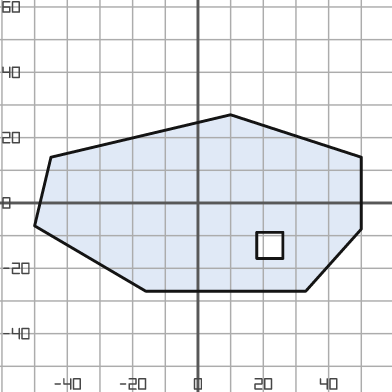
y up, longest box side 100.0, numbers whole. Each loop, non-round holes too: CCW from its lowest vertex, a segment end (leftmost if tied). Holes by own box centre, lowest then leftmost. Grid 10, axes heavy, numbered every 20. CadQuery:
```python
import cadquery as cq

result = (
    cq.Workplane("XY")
    .moveTo(-16.0, -27.0)
    .lineTo(33.0, -27.0)
    .lineTo(50.0, -8.0)
    .lineTo(50.0, 14.0)
    .lineTo(10.0, 27.0)
    .lineTo(-45.0, 14.0)
    .lineTo(-50.0, -7.0)
    .close()
    .moveTo(18.0, -17.0)
    .lineTo(26.0, -17.0)
    .lineTo(26.0, -9.0)
    .lineTo(18.0, -9.0)
    .close()
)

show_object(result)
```